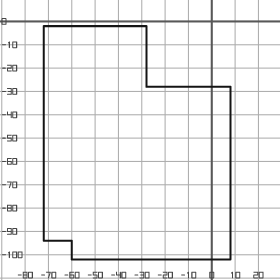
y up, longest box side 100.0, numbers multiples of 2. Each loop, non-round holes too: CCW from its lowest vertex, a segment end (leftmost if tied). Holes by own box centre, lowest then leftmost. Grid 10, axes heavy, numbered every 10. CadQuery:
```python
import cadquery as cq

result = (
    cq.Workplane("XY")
    .moveTo(-60.0, -102.0)
    .lineTo(8.0, -102.0)
    .lineTo(8.0, -28.0)
    .lineTo(-28.0, -28.0)
    .lineTo(-28.0, -2.0)
    .lineTo(-72.0, -2.0)
    .lineTo(-72.0, -94.0)
    .lineTo(-60.0, -94.0)
    .close()
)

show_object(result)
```